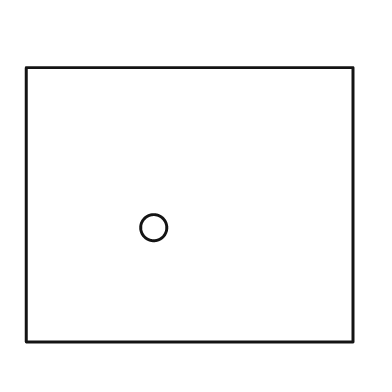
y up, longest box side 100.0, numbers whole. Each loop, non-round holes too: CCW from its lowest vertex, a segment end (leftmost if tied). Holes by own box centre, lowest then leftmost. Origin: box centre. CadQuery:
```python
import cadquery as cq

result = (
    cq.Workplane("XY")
    .moveTo(-50.0, -42.0)
    .lineTo(50.0, -42.0)
    .lineTo(50.0, 42.0)
    .lineTo(-50.0, 42.0)
    .close()
    .moveTo(-11.0, -7.0)
    .circle(4.0)
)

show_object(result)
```